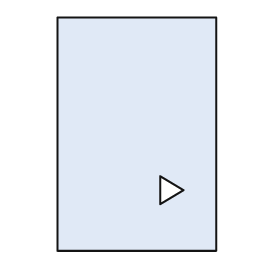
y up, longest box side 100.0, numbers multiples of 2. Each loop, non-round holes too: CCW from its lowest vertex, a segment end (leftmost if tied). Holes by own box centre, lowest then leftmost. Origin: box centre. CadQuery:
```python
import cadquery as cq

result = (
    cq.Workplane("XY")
    .moveTo(-34.0, -50.0)
    .lineTo(34.0, -50.0)
    .lineTo(34.0, 50.0)
    .lineTo(-34.0, 50.0)
    .close()
    .moveTo(10.0, -30.0)
    .lineTo(20.0, -24.0)
    .lineTo(10.0, -18.0)
    .close()
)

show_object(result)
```